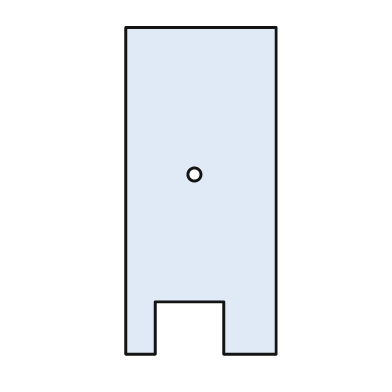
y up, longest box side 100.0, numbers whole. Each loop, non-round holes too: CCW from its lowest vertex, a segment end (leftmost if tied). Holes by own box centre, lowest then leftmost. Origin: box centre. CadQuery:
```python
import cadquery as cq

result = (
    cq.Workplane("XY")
    .moveTo(-23.0, -50.0)
    .lineTo(-14.0, -50.0)
    .lineTo(-14.0, -34.0)
    .lineTo(7.0, -34.0)
    .lineTo(7.0, -50.0)
    .lineTo(23.0, -50.0)
    .lineTo(23.0, 50.0)
    .lineTo(-23.0, 50.0)
    .close()
    .moveTo(-2.0, 5.0)
    .circle(2.0)
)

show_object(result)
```